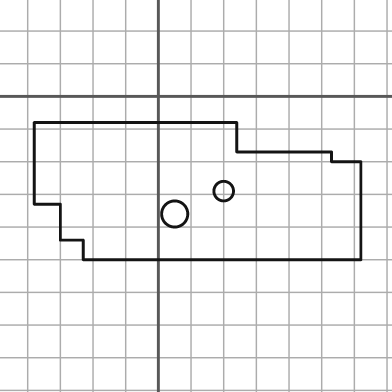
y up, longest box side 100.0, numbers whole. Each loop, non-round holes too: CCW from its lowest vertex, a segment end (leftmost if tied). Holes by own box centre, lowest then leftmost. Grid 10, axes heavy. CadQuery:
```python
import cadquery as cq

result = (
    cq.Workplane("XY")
    .moveTo(-23.0, -50.0)
    .lineTo(62.0, -50.0)
    .lineTo(62.0, -20.0)
    .lineTo(53.0, -20.0)
    .lineTo(53.0, -17.0)
    .lineTo(24.0, -17.0)
    .lineTo(24.0, -8.0)
    .lineTo(-38.0, -8.0)
    .lineTo(-38.0, -33.0)
    .lineTo(-30.0, -33.0)
    .lineTo(-30.0, -44.0)
    .lineTo(-23.0, -44.0)
    .close()
    .moveTo(5.0, -36.0)
    .circle(4.0)
    .moveTo(20.0, -29.0)
    .circle(3.0)
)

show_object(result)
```